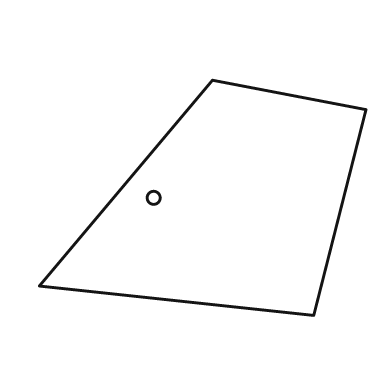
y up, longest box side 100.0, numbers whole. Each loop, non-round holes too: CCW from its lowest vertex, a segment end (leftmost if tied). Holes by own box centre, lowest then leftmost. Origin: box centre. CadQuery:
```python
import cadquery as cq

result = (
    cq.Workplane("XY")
    .moveTo(34.0, -36.0)
    .lineTo(50.0, 27.0)
    .lineTo(3.0, 36.0)
    .lineTo(-50.0, -27.0)
    .close()
    .moveTo(-15.0, 0.0)
    .circle(2.0)
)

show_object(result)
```